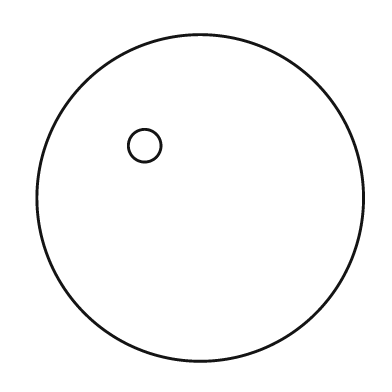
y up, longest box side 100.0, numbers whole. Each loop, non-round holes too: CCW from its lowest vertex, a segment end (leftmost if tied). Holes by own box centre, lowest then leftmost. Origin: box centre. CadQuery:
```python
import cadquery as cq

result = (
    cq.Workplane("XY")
    .moveTo(0.0, 0.0)
    .circle(50.0)
    .moveTo(-17.0, 16.0)
    .circle(5.0)
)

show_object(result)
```